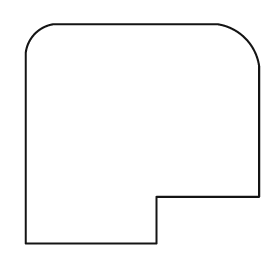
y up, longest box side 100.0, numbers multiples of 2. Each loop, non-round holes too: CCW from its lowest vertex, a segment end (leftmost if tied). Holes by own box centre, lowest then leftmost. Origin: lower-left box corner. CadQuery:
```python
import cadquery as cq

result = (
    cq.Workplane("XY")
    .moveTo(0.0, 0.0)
    .lineTo(56.0, 0.0)
    .lineTo(56.0, 20.0)
    .lineTo(100.0, 20.0)
    .lineTo(100.0, 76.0)
    .threePointArc((94.0, 88.0), (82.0, 94.0))
    .lineTo(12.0, 94.0)
    .threePointArc((4.0, 90.0), (0.0, 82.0))
    .close()
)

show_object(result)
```